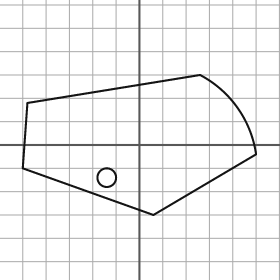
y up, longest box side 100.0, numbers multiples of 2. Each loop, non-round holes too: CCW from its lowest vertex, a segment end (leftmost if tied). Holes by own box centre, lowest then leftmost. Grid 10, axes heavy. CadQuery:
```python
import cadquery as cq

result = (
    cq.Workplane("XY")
    .moveTo(6.0, -30.0)
    .lineTo(50.0, -4.0)
    .threePointArc((42.0, 16.0), (26.0, 30.0))
    .lineTo(-48.0, 18.0)
    .lineTo(-50.0, -10.0)
    .close()
    .moveTo(-14.0, -14.0)
    .circle(4.0)
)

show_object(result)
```